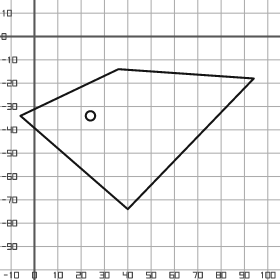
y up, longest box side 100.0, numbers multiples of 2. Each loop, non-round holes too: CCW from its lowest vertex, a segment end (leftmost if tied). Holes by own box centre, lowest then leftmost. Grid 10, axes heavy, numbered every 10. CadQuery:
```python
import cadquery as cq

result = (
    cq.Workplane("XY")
    .moveTo(40.0, -74.0)
    .lineTo(94.0, -18.0)
    .lineTo(36.0, -14.0)
    .lineTo(-6.0, -34.0)
    .close()
    .moveTo(24.0, -34.0)
    .circle(2.0)
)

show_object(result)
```